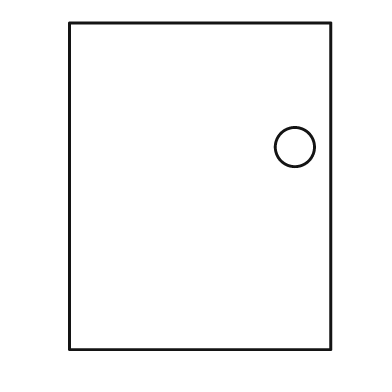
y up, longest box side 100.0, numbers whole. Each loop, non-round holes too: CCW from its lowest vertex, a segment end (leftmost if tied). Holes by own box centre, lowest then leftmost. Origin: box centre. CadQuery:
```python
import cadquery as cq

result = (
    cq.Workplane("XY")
    .moveTo(-40.0, -50.0)
    .lineTo(40.0, -50.0)
    .lineTo(40.0, 50.0)
    .lineTo(-40.0, 50.0)
    .close()
    .moveTo(29.0, 12.0)
    .circle(6.0)
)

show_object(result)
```